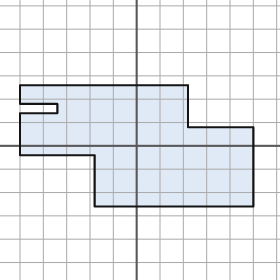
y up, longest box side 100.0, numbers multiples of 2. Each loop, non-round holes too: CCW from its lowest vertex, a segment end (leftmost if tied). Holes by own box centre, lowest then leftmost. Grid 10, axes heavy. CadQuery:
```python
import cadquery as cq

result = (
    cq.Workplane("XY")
    .moveTo(-18.0, -26.0)
    .lineTo(50.0, -26.0)
    .lineTo(50.0, 8.0)
    .lineTo(22.0, 8.0)
    .lineTo(22.0, 26.0)
    .lineTo(-50.0, 26.0)
    .lineTo(-50.0, 18.0)
    .lineTo(-34.0, 18.0)
    .lineTo(-34.0, 14.0)
    .lineTo(-50.0, 14.0)
    .lineTo(-50.0, -4.0)
    .lineTo(-18.0, -4.0)
    .close()
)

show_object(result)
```